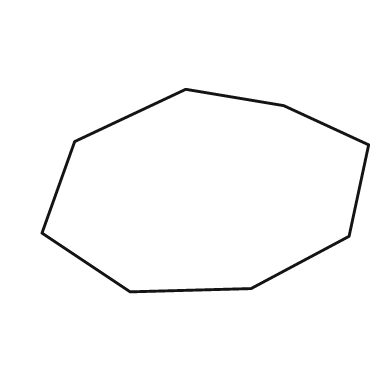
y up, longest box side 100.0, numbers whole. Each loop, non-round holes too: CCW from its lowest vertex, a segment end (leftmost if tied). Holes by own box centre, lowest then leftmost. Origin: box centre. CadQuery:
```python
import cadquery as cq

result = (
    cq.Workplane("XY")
    .moveTo(-23.0, -31.0)
    .lineTo(14.0, -30.0)
    .lineTo(44.0, -14.0)
    .lineTo(50.0, 14.0)
    .lineTo(24.0, 26.0)
    .lineTo(-6.0, 31.0)
    .lineTo(-40.0, 15.0)
    .lineTo(-50.0, -13.0)
    .close()
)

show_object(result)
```